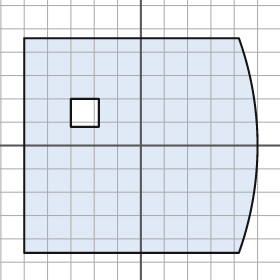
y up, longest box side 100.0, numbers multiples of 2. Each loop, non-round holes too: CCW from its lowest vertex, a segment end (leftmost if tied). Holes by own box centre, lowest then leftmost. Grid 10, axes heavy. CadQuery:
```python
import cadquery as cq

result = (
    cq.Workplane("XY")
    .moveTo(-50.0, -46.0)
    .lineTo(42.0, -46.0)
    .threePointArc((50.0, 0.0), (42.0, 46.0))
    .lineTo(-50.0, 46.0)
    .close()
    .moveTo(-30.0, 8.0)
    .lineTo(-18.0, 8.0)
    .lineTo(-18.0, 20.0)
    .lineTo(-30.0, 20.0)
    .close()
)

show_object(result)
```